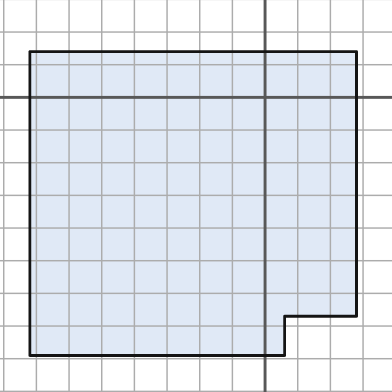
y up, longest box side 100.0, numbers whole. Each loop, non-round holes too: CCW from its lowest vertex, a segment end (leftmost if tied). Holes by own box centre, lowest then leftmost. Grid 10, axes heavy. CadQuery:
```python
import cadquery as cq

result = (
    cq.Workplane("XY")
    .moveTo(-72.0, -79.0)
    .lineTo(6.0, -79.0)
    .lineTo(6.0, -67.0)
    .lineTo(28.0, -67.0)
    .lineTo(28.0, 14.0)
    .lineTo(-72.0, 14.0)
    .close()
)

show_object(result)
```